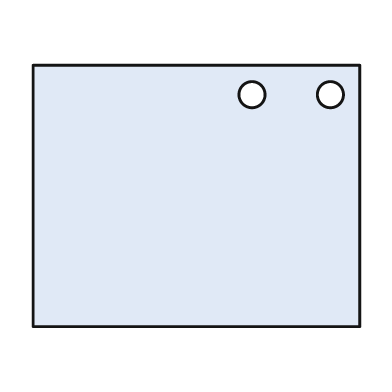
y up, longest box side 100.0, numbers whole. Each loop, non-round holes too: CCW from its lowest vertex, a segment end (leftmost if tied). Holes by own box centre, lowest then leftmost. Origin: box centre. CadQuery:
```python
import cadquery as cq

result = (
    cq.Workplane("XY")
    .moveTo(-50.0, -40.0)
    .lineTo(50.0, -40.0)
    .lineTo(50.0, 40.0)
    .lineTo(-50.0, 40.0)
    .close()
    .moveTo(17.0, 31.0)
    .circle(4.0)
    .moveTo(41.0, 31.0)
    .circle(4.0)
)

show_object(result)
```